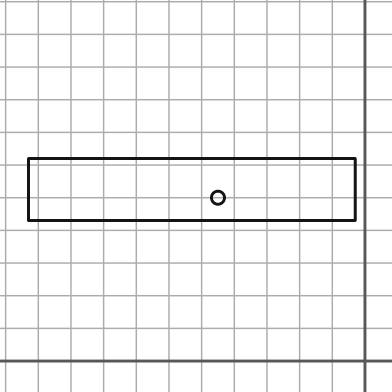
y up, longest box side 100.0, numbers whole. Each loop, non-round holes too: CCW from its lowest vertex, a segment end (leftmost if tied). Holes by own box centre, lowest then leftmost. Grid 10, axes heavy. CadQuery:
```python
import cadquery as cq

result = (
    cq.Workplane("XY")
    .moveTo(-103.0, 43.0)
    .lineTo(-3.0, 43.0)
    .lineTo(-3.0, 62.0)
    .lineTo(-103.0, 62.0)
    .close()
    .moveTo(-45.0, 50.0)
    .circle(2.0)
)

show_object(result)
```